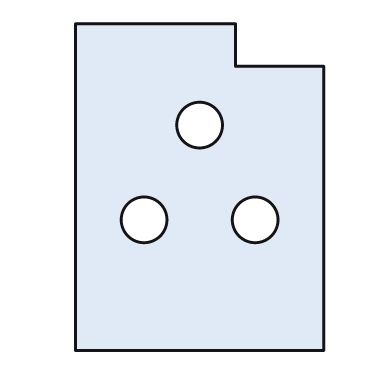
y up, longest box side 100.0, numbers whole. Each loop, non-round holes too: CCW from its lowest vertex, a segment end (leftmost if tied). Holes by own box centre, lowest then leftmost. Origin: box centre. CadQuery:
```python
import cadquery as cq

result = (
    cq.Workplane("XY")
    .moveTo(-38.0, -50.0)
    .lineTo(38.0, -50.0)
    .lineTo(38.0, 37.0)
    .lineTo(11.0, 37.0)
    .lineTo(11.0, 50.0)
    .lineTo(-38.0, 50.0)
    .close()
    .moveTo(-17.0, -10.0)
    .circle(7.0)
    .moveTo(17.0, -10.0)
    .circle(7.0)
    .moveTo(0.0, 19.0)
    .circle(7.0)
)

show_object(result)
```